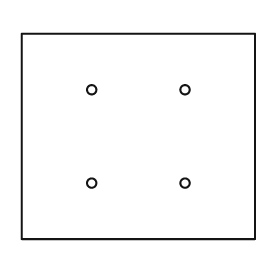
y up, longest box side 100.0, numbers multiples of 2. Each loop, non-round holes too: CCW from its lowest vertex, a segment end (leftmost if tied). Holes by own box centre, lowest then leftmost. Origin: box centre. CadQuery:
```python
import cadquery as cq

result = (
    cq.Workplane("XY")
    .moveTo(-50.0, -44.0)
    .lineTo(50.0, -44.0)
    .lineTo(50.0, 44.0)
    .lineTo(-50.0, 44.0)
    .close()
    .moveTo(-20.0, -20.0)
    .circle(2.0)
    .moveTo(20.0, -20.0)
    .circle(2.0)
    .moveTo(-20.0, 20.0)
    .circle(2.0)
    .moveTo(20.0, 20.0)
    .circle(2.0)
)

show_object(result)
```